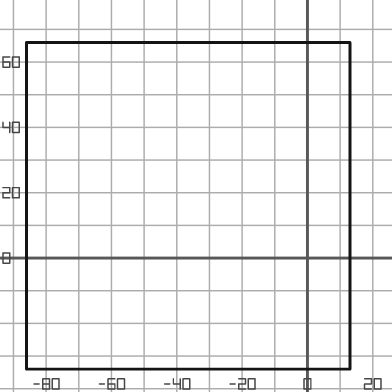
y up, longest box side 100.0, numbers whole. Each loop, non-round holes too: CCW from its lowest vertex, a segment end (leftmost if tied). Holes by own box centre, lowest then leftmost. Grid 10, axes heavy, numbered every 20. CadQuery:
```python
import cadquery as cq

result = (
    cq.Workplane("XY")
    .moveTo(-86.0, -34.0)
    .lineTo(13.0, -34.0)
    .lineTo(13.0, 66.0)
    .lineTo(-86.0, 66.0)
    .close()
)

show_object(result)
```